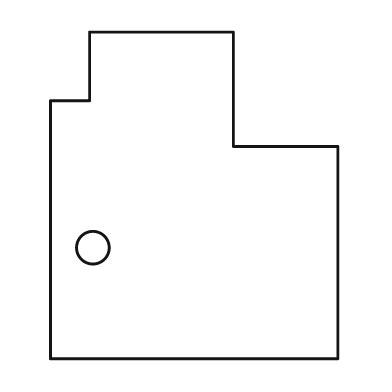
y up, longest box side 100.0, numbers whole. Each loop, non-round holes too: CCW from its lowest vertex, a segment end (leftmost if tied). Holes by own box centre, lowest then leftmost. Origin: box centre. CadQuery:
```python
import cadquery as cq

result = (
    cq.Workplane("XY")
    .moveTo(-44.0, -50.0)
    .lineTo(44.0, -50.0)
    .lineTo(44.0, 15.0)
    .lineTo(12.0, 15.0)
    .lineTo(12.0, 50.0)
    .lineTo(-32.0, 50.0)
    .lineTo(-32.0, 29.0)
    .lineTo(-44.0, 29.0)
    .close()
    .moveTo(-31.0, -16.0)
    .circle(5.0)
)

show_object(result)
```